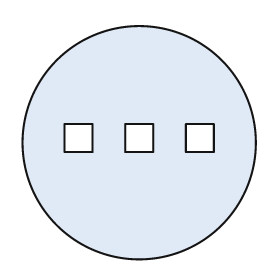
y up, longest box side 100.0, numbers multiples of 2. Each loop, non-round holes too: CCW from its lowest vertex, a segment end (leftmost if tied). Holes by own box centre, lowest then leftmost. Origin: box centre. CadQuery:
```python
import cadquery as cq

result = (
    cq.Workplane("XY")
    .moveTo(0.0, 0.0)
    .circle(50.0)
    .moveTo(-32.0, -4.0)
    .lineTo(-20.0, -4.0)
    .lineTo(-20.0, 8.0)
    .lineTo(-32.0, 8.0)
    .close()
    .moveTo(-6.0, -4.0)
    .lineTo(6.0, -4.0)
    .lineTo(6.0, 8.0)
    .lineTo(-6.0, 8.0)
    .close()
    .moveTo(20.0, -4.0)
    .lineTo(32.0, -4.0)
    .lineTo(32.0, 8.0)
    .lineTo(20.0, 8.0)
    .close()
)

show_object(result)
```